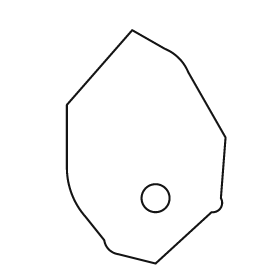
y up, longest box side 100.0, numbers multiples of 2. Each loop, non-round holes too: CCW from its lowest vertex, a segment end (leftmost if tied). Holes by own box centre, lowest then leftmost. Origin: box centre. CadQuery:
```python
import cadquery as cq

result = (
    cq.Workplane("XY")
    .moveTo(4.0, -50.0)
    .lineTo(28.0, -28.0)
    .threePointArc((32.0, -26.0), (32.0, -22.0))
    .lineTo(34.0, 4.0)
    .lineTo(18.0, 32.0)
    .threePointArc((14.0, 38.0), (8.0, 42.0))
    .lineTo(-6.0, 50.0)
    .lineTo(-34.0, 18.0)
    .lineTo(-34.0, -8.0)
    .threePointArc((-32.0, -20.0), (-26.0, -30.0))
    .lineTo(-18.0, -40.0)
    .threePointArc((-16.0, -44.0), (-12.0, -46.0))
    .close()
    .moveTo(4.0, -22.0)
    .circle(6.0)
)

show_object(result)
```